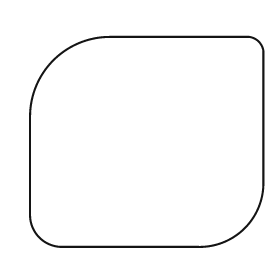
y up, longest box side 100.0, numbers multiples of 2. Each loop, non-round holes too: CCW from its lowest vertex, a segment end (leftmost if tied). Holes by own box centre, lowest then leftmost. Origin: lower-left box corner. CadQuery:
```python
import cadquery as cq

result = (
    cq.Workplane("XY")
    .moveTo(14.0, 0.0)
    .lineTo(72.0, 0.0)
    .threePointArc((92.0, 8.0), (100.0, 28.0))
    .lineTo(100.0, 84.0)
    .threePointArc((98.0, 88.0), (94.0, 90.0))
    .lineTo(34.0, 90.0)
    .threePointArc((10.0, 80.0), (0.0, 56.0))
    .lineTo(0.0, 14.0)
    .threePointArc((4.0, 4.0), (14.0, 0.0))
    .close()
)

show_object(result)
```